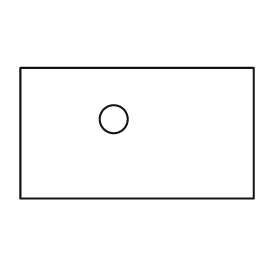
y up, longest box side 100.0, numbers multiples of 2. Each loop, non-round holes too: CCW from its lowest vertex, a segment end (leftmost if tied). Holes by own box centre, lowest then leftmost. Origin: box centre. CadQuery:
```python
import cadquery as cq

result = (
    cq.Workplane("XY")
    .moveTo(-50.0, -28.0)
    .lineTo(50.0, -28.0)
    .lineTo(50.0, 28.0)
    .lineTo(-50.0, 28.0)
    .close()
    .moveTo(-10.0, 6.0)
    .circle(6.0)
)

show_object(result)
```